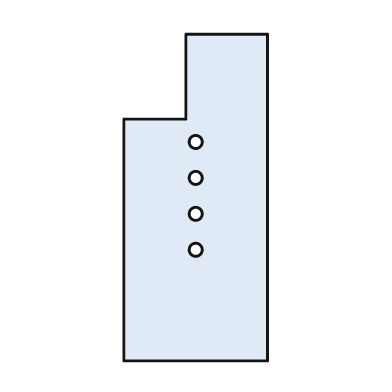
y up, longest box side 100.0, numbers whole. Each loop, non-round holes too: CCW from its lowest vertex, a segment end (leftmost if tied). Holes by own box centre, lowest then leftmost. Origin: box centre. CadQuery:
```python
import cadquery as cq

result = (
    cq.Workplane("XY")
    .moveTo(-22.0, -50.0)
    .lineTo(22.0, -50.0)
    .lineTo(22.0, 50.0)
    .lineTo(-3.0, 50.0)
    .lineTo(-3.0, 24.0)
    .lineTo(-22.0, 24.0)
    .close()
    .moveTo(0.0, -16.0)
    .circle(2.0)
    .moveTo(0.0, -5.0)
    .circle(2.0)
    .moveTo(0.0, 6.0)
    .circle(2.0)
    .moveTo(0.0, 17.0)
    .circle(2.0)
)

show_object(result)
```